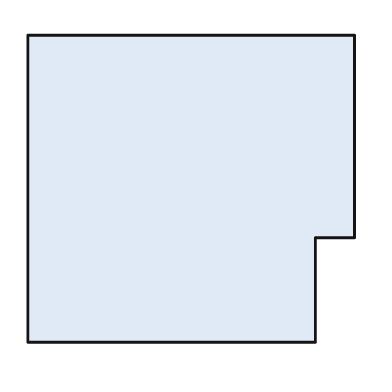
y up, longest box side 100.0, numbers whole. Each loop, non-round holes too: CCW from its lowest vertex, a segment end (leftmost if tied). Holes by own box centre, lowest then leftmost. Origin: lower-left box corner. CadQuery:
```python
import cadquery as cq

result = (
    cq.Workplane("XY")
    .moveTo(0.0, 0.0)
    .lineTo(88.0, 0.0)
    .lineTo(88.0, 32.0)
    .lineTo(100.0, 32.0)
    .lineTo(100.0, 94.0)
    .lineTo(0.0, 94.0)
    .close()
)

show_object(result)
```